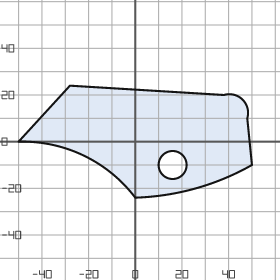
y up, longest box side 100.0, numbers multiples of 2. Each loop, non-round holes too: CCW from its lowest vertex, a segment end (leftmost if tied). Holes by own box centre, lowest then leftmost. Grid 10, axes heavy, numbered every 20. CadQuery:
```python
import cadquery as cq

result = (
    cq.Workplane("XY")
    .moveTo(0.0, -24.0)
    .threePointArc((26.0, -20.0), (50.0, -10.0))
    .lineTo(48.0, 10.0)
    .threePointArc((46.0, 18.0), (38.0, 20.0))
    .lineTo(-28.0, 24.0)
    .lineTo(-50.0, 0.0)
    .threePointArc((-22.0, -6.0), (0.0, -24.0))
    .close()
    .moveTo(16.0, -10.0)
    .circle(6.0)
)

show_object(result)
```